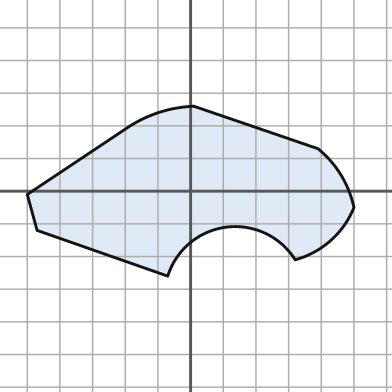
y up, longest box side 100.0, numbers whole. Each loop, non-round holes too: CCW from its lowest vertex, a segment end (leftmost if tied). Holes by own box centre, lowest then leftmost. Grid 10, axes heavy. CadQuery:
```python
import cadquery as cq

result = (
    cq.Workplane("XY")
    .moveTo(-7.0, -26.0)
    .threePointArc((11.0, -11.0), (32.0, -21.0))
    .threePointArc((43.0, -15.0), (50.0, -5.0))
    .threePointArc((46.0, 5.0), (39.0, 13.0))
    .lineTo(1.0, 26.0)
    .threePointArc((-10.0, 24.0), (-20.0, 19.0))
    .lineTo(-50.0, -1.0)
    .lineTo(-47.0, -12.0)
    .close()
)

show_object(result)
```